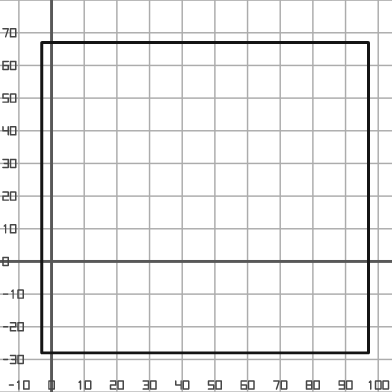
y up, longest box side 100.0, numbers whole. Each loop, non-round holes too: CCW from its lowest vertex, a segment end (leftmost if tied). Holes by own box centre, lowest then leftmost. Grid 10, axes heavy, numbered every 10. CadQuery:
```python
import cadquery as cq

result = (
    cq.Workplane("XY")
    .moveTo(-3.0, -28.0)
    .lineTo(97.0, -28.0)
    .lineTo(97.0, 67.0)
    .lineTo(-3.0, 67.0)
    .close()
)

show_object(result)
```